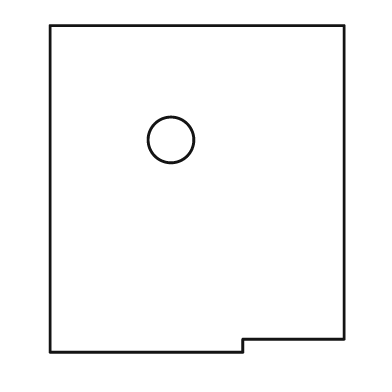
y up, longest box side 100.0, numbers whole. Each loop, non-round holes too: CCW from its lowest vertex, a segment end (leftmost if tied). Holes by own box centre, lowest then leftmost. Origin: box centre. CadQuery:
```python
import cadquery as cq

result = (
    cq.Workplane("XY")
    .moveTo(-45.0, -50.0)
    .lineTo(14.0, -50.0)
    .lineTo(14.0, -46.0)
    .lineTo(45.0, -46.0)
    .lineTo(45.0, 50.0)
    .lineTo(-45.0, 50.0)
    .close()
    .moveTo(-8.0, 15.0)
    .circle(7.0)
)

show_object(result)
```